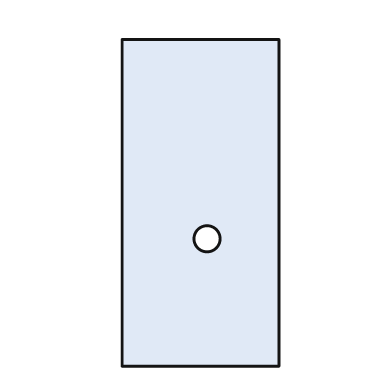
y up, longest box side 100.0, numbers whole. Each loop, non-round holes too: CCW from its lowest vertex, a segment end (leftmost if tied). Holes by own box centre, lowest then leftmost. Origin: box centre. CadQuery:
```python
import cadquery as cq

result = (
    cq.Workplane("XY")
    .moveTo(-24.0, -50.0)
    .lineTo(24.0, -50.0)
    .lineTo(24.0, 50.0)
    .lineTo(-24.0, 50.0)
    .close()
    .moveTo(2.0, -11.0)
    .circle(4.0)
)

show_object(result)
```